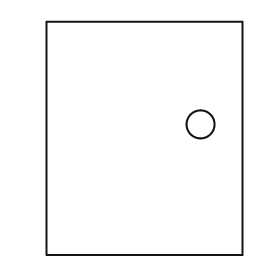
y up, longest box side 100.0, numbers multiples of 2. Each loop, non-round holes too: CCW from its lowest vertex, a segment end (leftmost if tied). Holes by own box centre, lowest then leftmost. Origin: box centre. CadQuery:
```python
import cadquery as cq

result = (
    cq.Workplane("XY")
    .moveTo(-42.0, -50.0)
    .lineTo(42.0, -50.0)
    .lineTo(42.0, 50.0)
    .lineTo(-42.0, 50.0)
    .close()
    .moveTo(24.0, 6.0)
    .circle(6.0)
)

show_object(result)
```